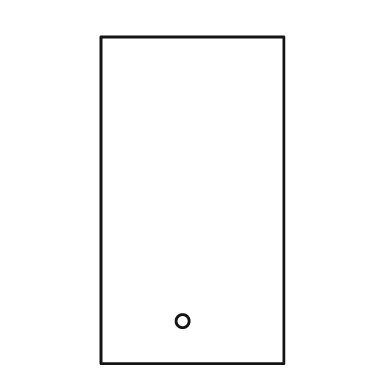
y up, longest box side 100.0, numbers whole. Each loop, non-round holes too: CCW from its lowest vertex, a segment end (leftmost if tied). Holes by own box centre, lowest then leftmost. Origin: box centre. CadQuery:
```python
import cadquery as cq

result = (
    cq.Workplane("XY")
    .moveTo(-28.0, -50.0)
    .lineTo(28.0, -50.0)
    .lineTo(28.0, 50.0)
    .lineTo(-28.0, 50.0)
    .close()
    .moveTo(-3.0, -37.0)
    .circle(2.0)
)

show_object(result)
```